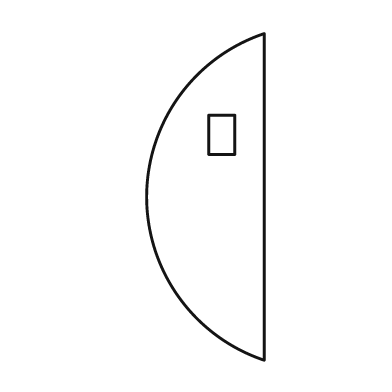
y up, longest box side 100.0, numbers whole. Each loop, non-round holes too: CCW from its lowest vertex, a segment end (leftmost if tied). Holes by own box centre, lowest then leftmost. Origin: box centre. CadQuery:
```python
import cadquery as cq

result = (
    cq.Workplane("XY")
    .moveTo(18.0, -50.0)
    .lineTo(18.0, 50.0)
    .threePointArc((-18.0, 0.0), (18.0, -50.0))
    .close()
    .moveTo(1.0, 13.0)
    .lineTo(9.0, 13.0)
    .lineTo(9.0, 25.0)
    .lineTo(1.0, 25.0)
    .close()
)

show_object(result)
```